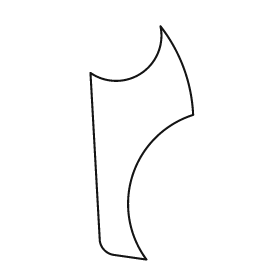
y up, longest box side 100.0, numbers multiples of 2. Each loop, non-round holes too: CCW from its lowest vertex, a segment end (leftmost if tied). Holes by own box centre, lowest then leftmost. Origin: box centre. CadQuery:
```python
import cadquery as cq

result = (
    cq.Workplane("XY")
    .moveTo(2.0, -50.0)
    .threePointArc((-4.0, -14.0), (22.0, 12.0))
    .threePointArc((18.0, 32.0), (8.0, 50.0))
    .threePointArc((0.0, 30.0), (-22.0, 30.0))
    .lineTo(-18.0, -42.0)
    .threePointArc((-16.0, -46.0), (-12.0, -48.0))
    .close()
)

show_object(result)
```